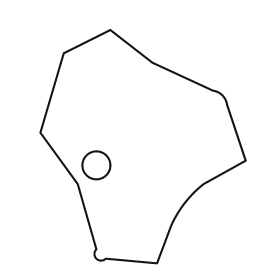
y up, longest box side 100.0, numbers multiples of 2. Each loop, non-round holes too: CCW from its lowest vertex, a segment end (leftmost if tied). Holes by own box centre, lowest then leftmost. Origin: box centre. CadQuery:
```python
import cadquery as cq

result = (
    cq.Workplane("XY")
    .moveTo(6.0, -50.0)
    .lineTo(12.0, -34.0)
    .threePointArc((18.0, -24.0), (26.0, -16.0))
    .lineTo(44.0, -6.0)
    .lineTo(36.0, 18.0)
    .threePointArc((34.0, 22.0), (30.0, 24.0))
    .lineTo(4.0, 36.0)
    .lineTo(-14.0, 50.0)
    .lineTo(-34.0, 40.0)
    .lineTo(-44.0, 6.0)
    .lineTo(-28.0, -16.0)
    .lineTo(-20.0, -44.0)
    .threePointArc((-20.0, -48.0), (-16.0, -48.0))
    .close()
    .moveTo(-20.0, -8.0)
    .circle(6.0)
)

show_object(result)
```